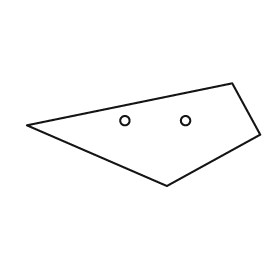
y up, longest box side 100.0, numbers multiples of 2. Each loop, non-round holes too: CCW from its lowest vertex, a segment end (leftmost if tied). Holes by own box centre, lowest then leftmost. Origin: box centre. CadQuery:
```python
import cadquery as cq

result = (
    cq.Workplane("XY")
    .moveTo(10.0, -22.0)
    .lineTo(50.0, 0.0)
    .lineTo(38.0, 22.0)
    .lineTo(-50.0, 4.0)
    .close()
    .moveTo(-8.0, 6.0)
    .circle(2.0)
    .moveTo(18.0, 6.0)
    .circle(2.0)
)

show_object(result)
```